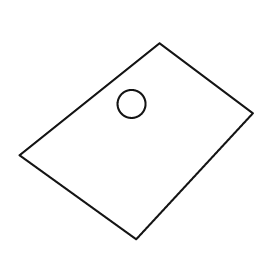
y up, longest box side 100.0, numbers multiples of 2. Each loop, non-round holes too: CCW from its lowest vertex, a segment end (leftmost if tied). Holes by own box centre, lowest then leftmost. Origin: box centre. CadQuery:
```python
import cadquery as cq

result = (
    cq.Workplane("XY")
    .moveTo(0.0, -42.0)
    .lineTo(50.0, 12.0)
    .lineTo(10.0, 42.0)
    .lineTo(-50.0, -6.0)
    .close()
    .moveTo(-2.0, 16.0)
    .circle(6.0)
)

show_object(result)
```